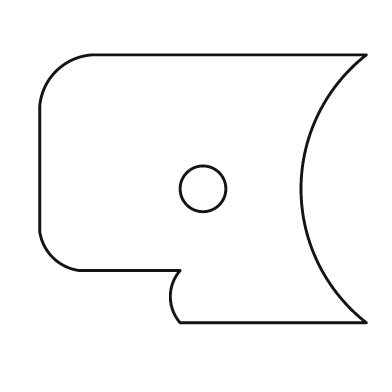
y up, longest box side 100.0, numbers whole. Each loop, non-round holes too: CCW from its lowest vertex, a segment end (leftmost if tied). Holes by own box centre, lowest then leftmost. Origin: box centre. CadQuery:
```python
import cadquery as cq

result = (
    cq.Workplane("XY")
    .moveTo(-7.0, -41.0)
    .lineTo(50.0, -41.0)
    .threePointArc((30.0, 0.0), (50.0, 41.0))
    .lineTo(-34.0, 41.0)
    .threePointArc((-45.0, 36.0), (-50.0, 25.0))
    .lineTo(-50.0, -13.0)
    .threePointArc((-46.0, -21.0), (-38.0, -25.0))
    .lineTo(-7.0, -25.0)
    .threePointArc((-10.0, -33.0), (-7.0, -41.0))
    .close()
    .moveTo(0.0, 0.0)
    .circle(7.0)
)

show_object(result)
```